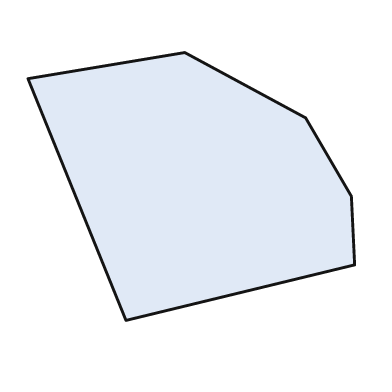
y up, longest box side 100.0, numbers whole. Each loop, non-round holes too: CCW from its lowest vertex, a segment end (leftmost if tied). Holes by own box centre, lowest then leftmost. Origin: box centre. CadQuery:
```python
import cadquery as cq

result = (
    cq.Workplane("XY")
    .moveTo(-20.0, -41.0)
    .lineTo(50.0, -24.0)
    .lineTo(49.0, -3.0)
    .lineTo(35.0, 21.0)
    .lineTo(-2.0, 41.0)
    .lineTo(-50.0, 33.0)
    .close()
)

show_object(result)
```